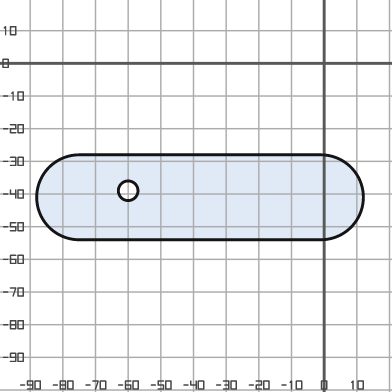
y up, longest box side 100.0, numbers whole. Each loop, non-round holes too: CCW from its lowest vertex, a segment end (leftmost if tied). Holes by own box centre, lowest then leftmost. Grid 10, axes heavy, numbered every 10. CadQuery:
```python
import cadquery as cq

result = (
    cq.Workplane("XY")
    .moveTo(-75.0, -54.0)
    .lineTo(-1.0, -54.0)
    .threePointArc((12.0, -41.0), (-1.0, -28.0))
    .lineTo(-75.0, -28.0)
    .threePointArc((-88.0, -41.0), (-75.0, -54.0))
    .close()
    .moveTo(-60.0, -39.0)
    .circle(3.0)
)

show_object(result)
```